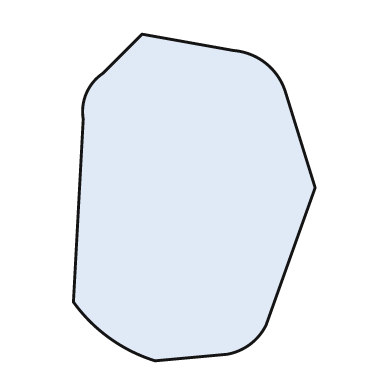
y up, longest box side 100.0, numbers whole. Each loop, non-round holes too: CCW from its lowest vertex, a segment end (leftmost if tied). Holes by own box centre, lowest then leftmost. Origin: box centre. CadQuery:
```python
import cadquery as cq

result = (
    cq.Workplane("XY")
    .moveTo(-12.0, -50.0)
    .lineTo(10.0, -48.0)
    .threePointArc((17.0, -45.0), (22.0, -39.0))
    .lineTo(37.0, 3.0)
    .lineTo(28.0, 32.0)
    .threePointArc((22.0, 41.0), (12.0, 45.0))
    .lineTo(-16.0, 50.0)
    .lineTo(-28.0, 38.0)
    .threePointArc((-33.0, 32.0), (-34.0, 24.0))
    .lineTo(-37.0, -32.0)
    .threePointArc((-26.0, -43.0), (-12.0, -50.0))
    .close()
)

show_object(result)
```